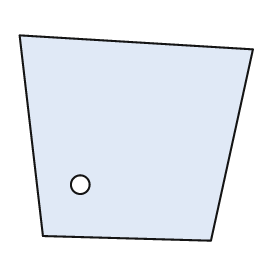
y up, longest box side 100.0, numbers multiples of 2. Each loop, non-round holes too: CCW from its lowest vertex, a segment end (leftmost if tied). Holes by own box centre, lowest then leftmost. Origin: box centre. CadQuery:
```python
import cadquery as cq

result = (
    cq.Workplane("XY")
    .moveTo(32.0, -44.0)
    .lineTo(50.0, 38.0)
    .lineTo(-50.0, 44.0)
    .lineTo(-40.0, -42.0)
    .close()
    .moveTo(-24.0, -20.0)
    .circle(4.0)
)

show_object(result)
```